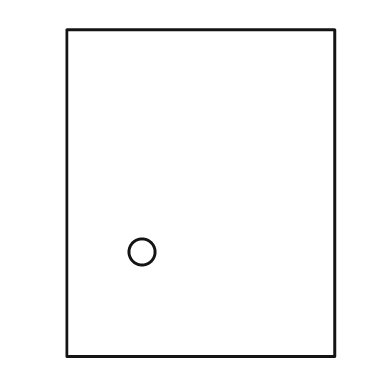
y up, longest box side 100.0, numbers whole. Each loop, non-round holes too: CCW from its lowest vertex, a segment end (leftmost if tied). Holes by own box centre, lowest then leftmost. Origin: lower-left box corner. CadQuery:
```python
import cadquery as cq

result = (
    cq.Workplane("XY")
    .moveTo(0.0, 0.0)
    .lineTo(82.0, 0.0)
    .lineTo(82.0, 100.0)
    .lineTo(0.0, 100.0)
    .close()
    .moveTo(23.0, 32.0)
    .circle(4.0)
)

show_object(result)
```